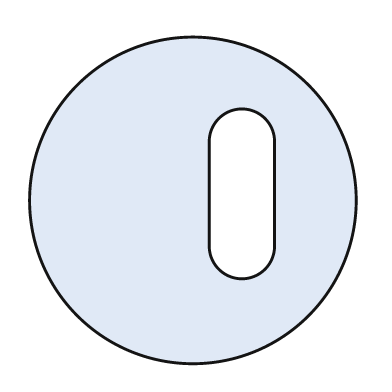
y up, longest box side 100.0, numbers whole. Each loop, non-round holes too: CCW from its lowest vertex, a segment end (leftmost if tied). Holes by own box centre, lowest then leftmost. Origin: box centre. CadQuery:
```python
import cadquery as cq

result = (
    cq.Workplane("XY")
    .moveTo(0.0, 0.0)
    .circle(50.0)
    .moveTo(5.0, -14.0)
    .threePointArc((15.0, -24.0), (25.0, -14.0))
    .lineTo(25.0, 18.0)
    .threePointArc((15.0, 28.0), (5.0, 18.0))
    .close()
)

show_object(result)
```